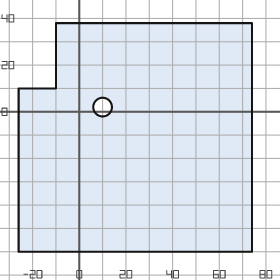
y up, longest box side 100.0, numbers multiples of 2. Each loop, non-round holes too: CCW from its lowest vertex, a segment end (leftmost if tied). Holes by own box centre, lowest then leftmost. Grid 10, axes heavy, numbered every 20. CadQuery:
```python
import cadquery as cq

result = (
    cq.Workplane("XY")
    .moveTo(-26.0, -60.0)
    .lineTo(74.0, -60.0)
    .lineTo(74.0, 38.0)
    .lineTo(-10.0, 38.0)
    .lineTo(-10.0, 10.0)
    .lineTo(-26.0, 10.0)
    .close()
    .moveTo(10.0, 2.0)
    .circle(4.0)
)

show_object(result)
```